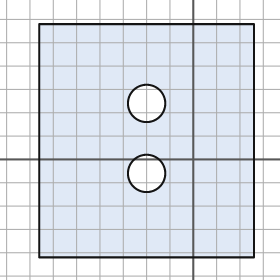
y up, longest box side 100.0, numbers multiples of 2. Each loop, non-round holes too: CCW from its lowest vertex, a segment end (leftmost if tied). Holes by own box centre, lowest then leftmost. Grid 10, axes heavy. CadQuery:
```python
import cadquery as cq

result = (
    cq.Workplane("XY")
    .moveTo(-66.0, -42.0)
    .lineTo(26.0, -42.0)
    .lineTo(26.0, 58.0)
    .lineTo(-66.0, 58.0)
    .close()
    .moveTo(-20.0, -6.0)
    .circle(8.0)
    .moveTo(-20.0, 24.0)
    .circle(8.0)
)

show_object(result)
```